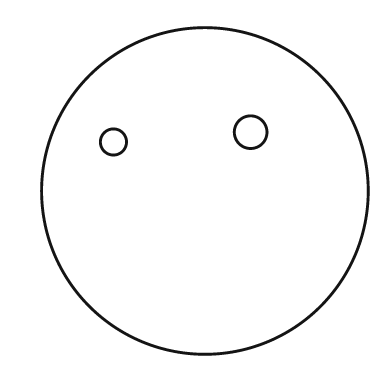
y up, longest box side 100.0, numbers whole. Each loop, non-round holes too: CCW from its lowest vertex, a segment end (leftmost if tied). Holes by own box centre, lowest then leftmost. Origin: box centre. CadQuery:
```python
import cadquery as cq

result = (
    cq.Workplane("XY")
    .moveTo(0.0, 0.0)
    .circle(50.0)
    .moveTo(-28.0, 15.0)
    .circle(4.0)
    .moveTo(14.0, 18.0)
    .circle(5.0)
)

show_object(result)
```